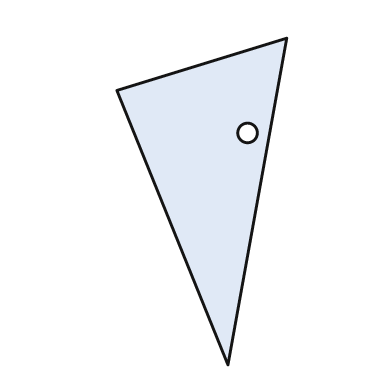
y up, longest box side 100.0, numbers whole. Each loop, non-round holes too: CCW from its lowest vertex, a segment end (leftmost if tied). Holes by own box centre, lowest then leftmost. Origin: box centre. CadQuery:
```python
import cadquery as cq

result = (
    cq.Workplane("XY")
    .moveTo(8.0, -50.0)
    .lineTo(26.0, 50.0)
    .lineTo(-26.0, 34.0)
    .close()
    .moveTo(14.0, 21.0)
    .circle(3.0)
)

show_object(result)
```